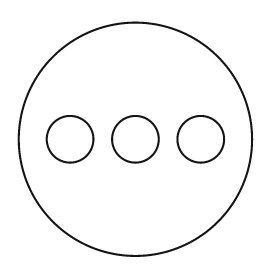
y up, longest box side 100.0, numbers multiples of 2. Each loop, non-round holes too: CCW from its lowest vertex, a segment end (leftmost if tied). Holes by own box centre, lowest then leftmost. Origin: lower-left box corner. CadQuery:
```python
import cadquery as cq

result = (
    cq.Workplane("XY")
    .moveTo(50.0, 50.0)
    .circle(50.0)
    .moveTo(22.0, 50.0)
    .circle(10.0)
    .moveTo(50.0, 50.0)
    .circle(10.0)
    .moveTo(78.0, 50.0)
    .circle(10.0)
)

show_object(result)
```